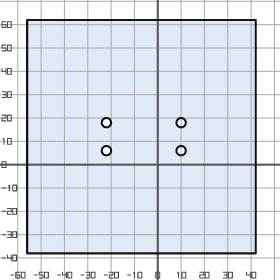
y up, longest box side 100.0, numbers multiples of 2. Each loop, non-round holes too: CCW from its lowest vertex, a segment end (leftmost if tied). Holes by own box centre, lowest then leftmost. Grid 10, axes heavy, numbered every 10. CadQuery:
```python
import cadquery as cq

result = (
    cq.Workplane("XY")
    .moveTo(-56.0, -38.0)
    .lineTo(42.0, -38.0)
    .lineTo(42.0, 62.0)
    .lineTo(-56.0, 62.0)
    .close()
    .moveTo(-22.0, 6.0)
    .circle(2.0)
    .moveTo(10.0, 6.0)
    .circle(2.0)
    .moveTo(-22.0, 18.0)
    .circle(2.0)
    .moveTo(10.0, 18.0)
    .circle(2.0)
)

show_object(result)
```